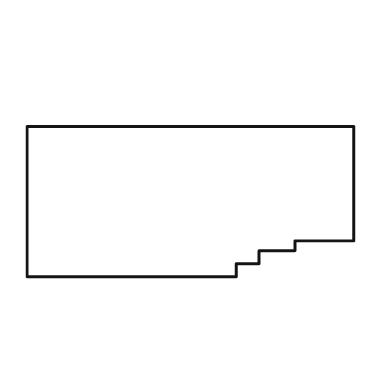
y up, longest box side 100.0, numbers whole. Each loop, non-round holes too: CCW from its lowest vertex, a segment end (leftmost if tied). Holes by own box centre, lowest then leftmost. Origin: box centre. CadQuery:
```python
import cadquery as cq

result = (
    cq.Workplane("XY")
    .moveTo(-50.0, -23.0)
    .lineTo(14.0, -23.0)
    .lineTo(14.0, -19.0)
    .lineTo(21.0, -19.0)
    .lineTo(21.0, -15.0)
    .lineTo(32.0, -15.0)
    .lineTo(32.0, -12.0)
    .lineTo(50.0, -12.0)
    .lineTo(50.0, 23.0)
    .lineTo(-50.0, 23.0)
    .close()
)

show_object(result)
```